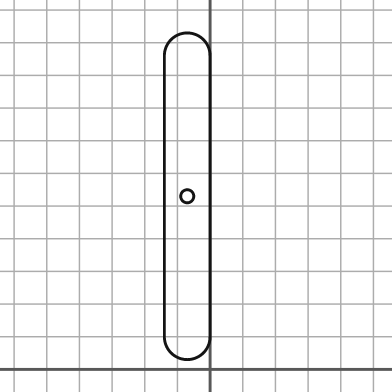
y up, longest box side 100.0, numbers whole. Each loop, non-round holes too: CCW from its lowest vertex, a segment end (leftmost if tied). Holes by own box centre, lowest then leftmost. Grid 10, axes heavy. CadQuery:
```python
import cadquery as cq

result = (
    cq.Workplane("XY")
    .moveTo(-14.0, 10.0)
    .threePointArc((-7.0, 3.0), (0.0, 10.0))
    .lineTo(0.0, 96.0)
    .threePointArc((-7.0, 103.0), (-14.0, 96.0))
    .close()
    .moveTo(-7.0, 53.0)
    .circle(2.0)
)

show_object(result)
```